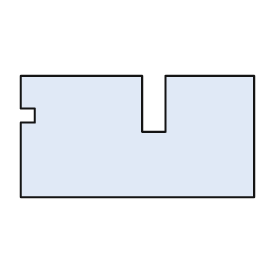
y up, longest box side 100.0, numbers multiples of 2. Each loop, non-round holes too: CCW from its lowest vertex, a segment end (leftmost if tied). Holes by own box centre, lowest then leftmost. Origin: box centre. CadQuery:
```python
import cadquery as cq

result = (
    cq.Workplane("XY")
    .moveTo(-50.0, -26.0)
    .lineTo(50.0, -26.0)
    .lineTo(50.0, 26.0)
    .lineTo(12.0, 26.0)
    .lineTo(12.0, 2.0)
    .lineTo(2.0, 2.0)
    .lineTo(2.0, 26.0)
    .lineTo(-50.0, 26.0)
    .lineTo(-50.0, 12.0)
    .lineTo(-44.0, 12.0)
    .lineTo(-44.0, 6.0)
    .lineTo(-50.0, 6.0)
    .close()
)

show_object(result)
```